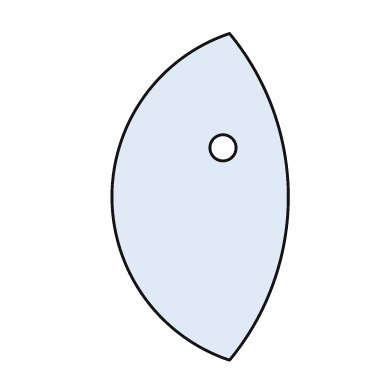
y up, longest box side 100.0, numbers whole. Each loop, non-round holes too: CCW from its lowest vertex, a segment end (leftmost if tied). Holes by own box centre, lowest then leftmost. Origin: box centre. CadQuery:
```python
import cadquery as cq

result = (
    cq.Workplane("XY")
    .moveTo(9.0, -50.0)
    .threePointArc((27.0, 0.0), (9.0, 50.0))
    .threePointArc((-27.0, 0.0), (9.0, -50.0))
    .close()
    .moveTo(7.0, 15.0)
    .circle(4.0)
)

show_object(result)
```